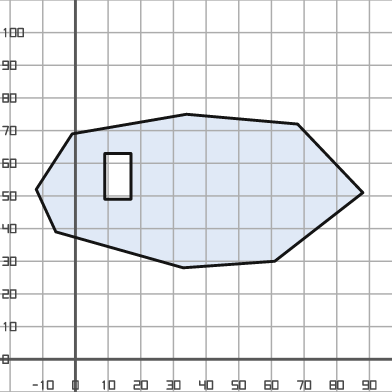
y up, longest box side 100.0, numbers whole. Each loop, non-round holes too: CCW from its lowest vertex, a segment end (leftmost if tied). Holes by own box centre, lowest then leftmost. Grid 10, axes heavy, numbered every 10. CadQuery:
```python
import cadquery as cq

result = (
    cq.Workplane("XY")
    .moveTo(33.0, 28.0)
    .lineTo(61.0, 30.0)
    .lineTo(88.0, 51.0)
    .lineTo(68.0, 72.0)
    .lineTo(34.0, 75.0)
    .lineTo(-1.0, 69.0)
    .lineTo(-12.0, 52.0)
    .lineTo(-6.0, 39.0)
    .close()
    .moveTo(9.0, 49.0)
    .lineTo(17.0, 49.0)
    .lineTo(17.0, 63.0)
    .lineTo(9.0, 63.0)
    .close()
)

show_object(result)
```